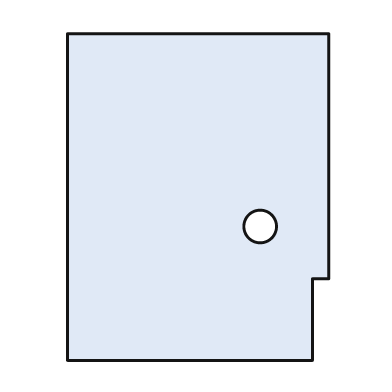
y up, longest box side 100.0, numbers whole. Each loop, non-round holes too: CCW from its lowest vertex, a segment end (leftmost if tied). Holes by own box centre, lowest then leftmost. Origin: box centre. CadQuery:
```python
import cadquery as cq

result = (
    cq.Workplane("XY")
    .moveTo(-40.0, -50.0)
    .lineTo(35.0, -50.0)
    .lineTo(35.0, -25.0)
    .lineTo(40.0, -25.0)
    .lineTo(40.0, 50.0)
    .lineTo(-40.0, 50.0)
    .close()
    .moveTo(19.0, -9.0)
    .circle(5.0)
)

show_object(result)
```